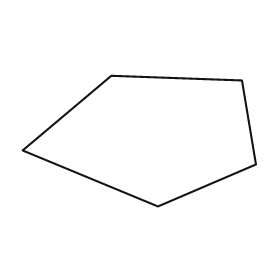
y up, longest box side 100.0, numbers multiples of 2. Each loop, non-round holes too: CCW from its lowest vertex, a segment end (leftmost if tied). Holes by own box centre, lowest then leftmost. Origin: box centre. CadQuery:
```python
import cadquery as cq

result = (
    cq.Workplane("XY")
    .moveTo(8.0, -28.0)
    .lineTo(50.0, -10.0)
    .lineTo(44.0, 26.0)
    .lineTo(-12.0, 28.0)
    .lineTo(-50.0, -4.0)
    .close()
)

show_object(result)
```